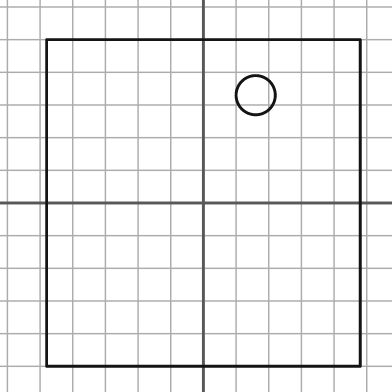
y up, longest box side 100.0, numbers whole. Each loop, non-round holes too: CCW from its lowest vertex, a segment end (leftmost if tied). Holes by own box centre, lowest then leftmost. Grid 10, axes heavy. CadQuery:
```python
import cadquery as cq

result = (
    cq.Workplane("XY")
    .moveTo(-48.0, -50.0)
    .lineTo(48.0, -50.0)
    .lineTo(48.0, 50.0)
    .lineTo(-48.0, 50.0)
    .close()
    .moveTo(16.0, 33.0)
    .circle(6.0)
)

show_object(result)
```